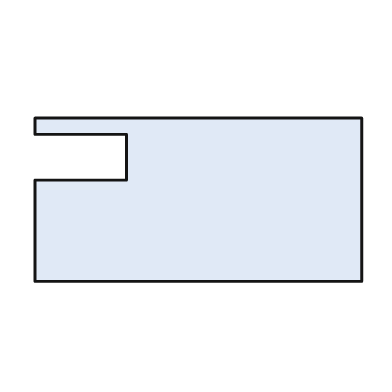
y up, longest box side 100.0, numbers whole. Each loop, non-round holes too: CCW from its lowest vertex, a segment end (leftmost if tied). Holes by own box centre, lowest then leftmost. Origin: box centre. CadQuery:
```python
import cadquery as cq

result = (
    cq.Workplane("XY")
    .moveTo(-50.0, -25.0)
    .lineTo(50.0, -25.0)
    .lineTo(50.0, 25.0)
    .lineTo(-50.0, 25.0)
    .lineTo(-50.0, 20.0)
    .lineTo(-22.0, 20.0)
    .lineTo(-22.0, 6.0)
    .lineTo(-50.0, 6.0)
    .close()
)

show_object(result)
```